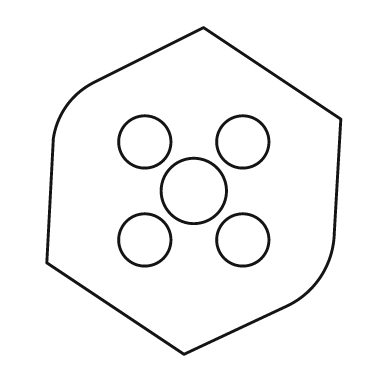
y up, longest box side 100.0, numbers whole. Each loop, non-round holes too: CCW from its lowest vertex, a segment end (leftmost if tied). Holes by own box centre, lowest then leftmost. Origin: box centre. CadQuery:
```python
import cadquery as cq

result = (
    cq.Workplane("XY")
    .moveTo(-3.0, -50.0)
    .lineTo(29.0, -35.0)
    .threePointArc((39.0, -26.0), (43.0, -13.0))
    .lineTo(45.0, 22.0)
    .lineTo(3.0, 50.0)
    .lineTo(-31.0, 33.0)
    .threePointArc((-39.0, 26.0), (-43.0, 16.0))
    .lineTo(-45.0, -22.0)
    .close()
    .moveTo(-15.0, -15.0)
    .circle(8.0)
    .moveTo(15.0, -15.0)
    .circle(8.0)
    .moveTo(0.0, 0.0)
    .circle(10.0)
    .moveTo(-15.0, 15.0)
    .circle(8.0)
    .moveTo(15.0, 15.0)
    .circle(8.0)
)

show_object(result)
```